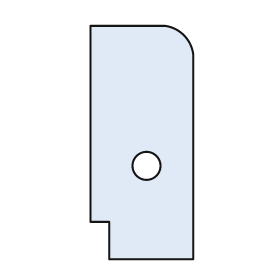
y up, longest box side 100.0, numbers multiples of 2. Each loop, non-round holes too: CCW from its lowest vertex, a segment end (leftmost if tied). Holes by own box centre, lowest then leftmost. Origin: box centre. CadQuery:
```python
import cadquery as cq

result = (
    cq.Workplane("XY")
    .moveTo(-14.0, -50.0)
    .lineTo(22.0, -50.0)
    .lineTo(22.0, 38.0)
    .threePointArc((18.0, 46.0), (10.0, 50.0))
    .lineTo(-22.0, 50.0)
    .lineTo(-22.0, -34.0)
    .lineTo(-14.0, -34.0)
    .close()
    .moveTo(2.0, -10.0)
    .circle(6.0)
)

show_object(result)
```